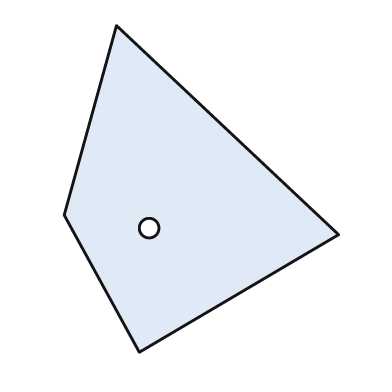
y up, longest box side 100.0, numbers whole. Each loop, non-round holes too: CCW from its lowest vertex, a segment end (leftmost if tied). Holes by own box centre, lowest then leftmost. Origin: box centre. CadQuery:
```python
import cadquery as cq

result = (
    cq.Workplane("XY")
    .moveTo(-19.0, -50.0)
    .lineTo(42.0, -14.0)
    .lineTo(-26.0, 50.0)
    .lineTo(-42.0, -8.0)
    .close()
    .moveTo(-16.0, -12.0)
    .circle(3.0)
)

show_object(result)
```